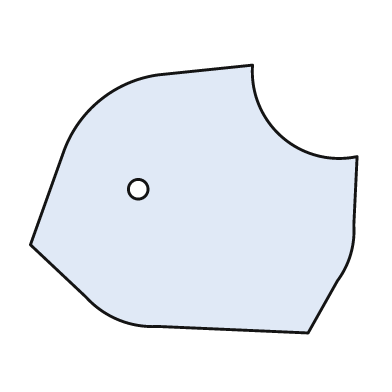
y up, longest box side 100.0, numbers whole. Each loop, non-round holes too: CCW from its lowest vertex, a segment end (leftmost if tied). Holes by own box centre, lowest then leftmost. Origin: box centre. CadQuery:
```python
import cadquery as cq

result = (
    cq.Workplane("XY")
    .moveTo(35.0, -41.0)
    .lineTo(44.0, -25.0)
    .threePointArc((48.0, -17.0), (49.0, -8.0))
    .lineTo(50.0, 13.0)
    .threePointArc((27.0, 19.0), (18.0, 41.0))
    .lineTo(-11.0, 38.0)
    .threePointArc((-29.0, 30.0), (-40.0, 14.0))
    .lineTo(-50.0, -14.0)
    .lineTo(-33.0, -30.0)
    .threePointArc((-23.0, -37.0), (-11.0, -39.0))
    .close()
    .moveTo(-17.0, 3.0)
    .circle(3.0)
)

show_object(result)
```